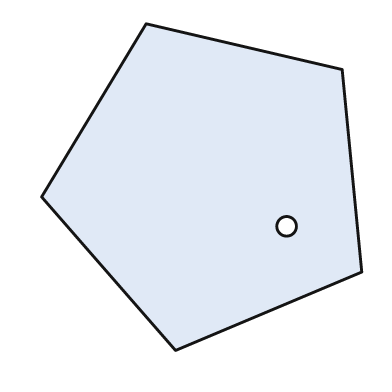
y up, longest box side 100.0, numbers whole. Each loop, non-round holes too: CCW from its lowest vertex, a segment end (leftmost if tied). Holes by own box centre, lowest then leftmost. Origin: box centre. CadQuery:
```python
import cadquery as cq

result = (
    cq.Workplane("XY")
    .moveTo(-8.0, -50.0)
    .lineTo(49.0, -26.0)
    .lineTo(43.0, 36.0)
    .lineTo(-17.0, 50.0)
    .lineTo(-49.0, -3.0)
    .close()
    .moveTo(26.0, -12.0)
    .circle(3.0)
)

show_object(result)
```